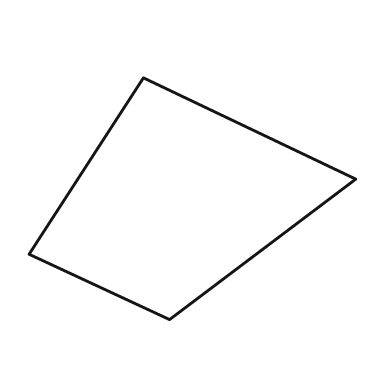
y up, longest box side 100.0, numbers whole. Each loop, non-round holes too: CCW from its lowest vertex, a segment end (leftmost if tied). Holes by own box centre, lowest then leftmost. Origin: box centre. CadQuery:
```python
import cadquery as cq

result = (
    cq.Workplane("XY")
    .moveTo(-7.0, -37.0)
    .lineTo(50.0, 6.0)
    .lineTo(-15.0, 37.0)
    .lineTo(-50.0, -17.0)
    .close()
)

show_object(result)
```